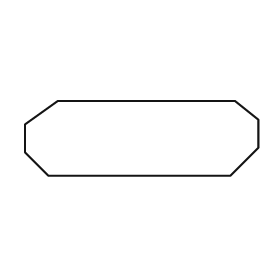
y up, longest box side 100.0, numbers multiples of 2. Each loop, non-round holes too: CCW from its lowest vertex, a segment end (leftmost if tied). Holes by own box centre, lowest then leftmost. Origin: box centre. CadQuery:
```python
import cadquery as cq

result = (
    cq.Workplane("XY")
    .moveTo(-40.0, -16.0)
    .lineTo(38.0, -16.0)
    .lineTo(50.0, -4.0)
    .lineTo(50.0, 8.0)
    .lineTo(40.0, 16.0)
    .lineTo(-36.0, 16.0)
    .lineTo(-50.0, 6.0)
    .lineTo(-50.0, -6.0)
    .close()
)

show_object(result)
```